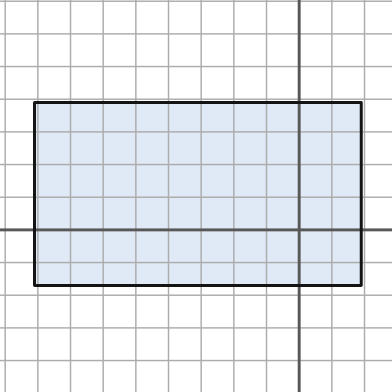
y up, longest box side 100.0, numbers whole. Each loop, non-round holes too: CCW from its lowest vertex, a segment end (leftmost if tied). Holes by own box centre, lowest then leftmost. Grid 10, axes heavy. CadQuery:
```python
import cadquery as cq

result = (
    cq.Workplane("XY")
    .moveTo(-81.0, -17.0)
    .lineTo(19.0, -17.0)
    .lineTo(19.0, 39.0)
    .lineTo(-81.0, 39.0)
    .close()
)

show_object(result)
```